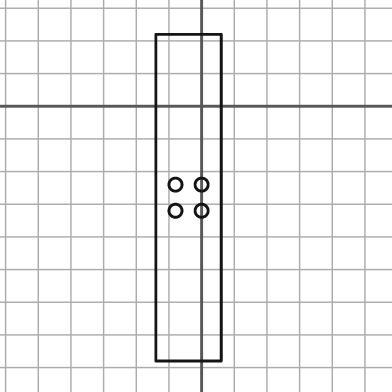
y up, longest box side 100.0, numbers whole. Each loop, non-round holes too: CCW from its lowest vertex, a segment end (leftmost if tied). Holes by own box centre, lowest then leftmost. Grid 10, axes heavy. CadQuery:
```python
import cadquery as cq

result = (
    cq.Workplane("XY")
    .moveTo(-14.0, -78.0)
    .lineTo(6.0, -78.0)
    .lineTo(6.0, 22.0)
    .lineTo(-14.0, 22.0)
    .close()
    .moveTo(-8.0, -32.0)
    .circle(2.0)
    .moveTo(0.0, -32.0)
    .circle(2.0)
    .moveTo(-8.0, -24.0)
    .circle(2.0)
    .moveTo(0.0, -24.0)
    .circle(2.0)
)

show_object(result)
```